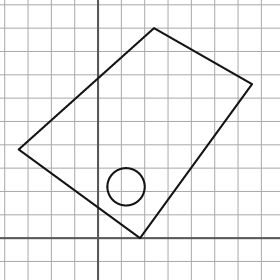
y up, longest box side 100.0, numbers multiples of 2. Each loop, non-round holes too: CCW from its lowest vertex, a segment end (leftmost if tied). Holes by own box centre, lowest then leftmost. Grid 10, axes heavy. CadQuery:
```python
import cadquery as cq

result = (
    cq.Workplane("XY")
    .moveTo(18.0, 0.0)
    .lineTo(66.0, 66.0)
    .lineTo(24.0, 90.0)
    .lineTo(-34.0, 38.0)
    .close()
    .moveTo(12.0, 22.0)
    .circle(8.0)
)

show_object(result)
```